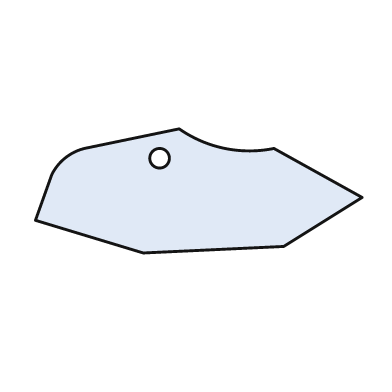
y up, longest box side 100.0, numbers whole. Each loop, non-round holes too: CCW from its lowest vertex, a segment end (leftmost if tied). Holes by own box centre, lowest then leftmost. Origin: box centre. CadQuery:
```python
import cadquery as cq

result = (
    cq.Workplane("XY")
    .moveTo(-17.0, -19.0)
    .lineTo(26.0, -17.0)
    .lineTo(50.0, -2.0)
    .lineTo(23.0, 13.0)
    .threePointArc((8.0, 13.0), (-6.0, 19.0))
    .lineTo(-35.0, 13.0)
    .threePointArc((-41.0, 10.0), (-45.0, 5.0))
    .lineTo(-50.0, -9.0)
    .close()
    .moveTo(-12.0, 10.0)
    .circle(3.0)
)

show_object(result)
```